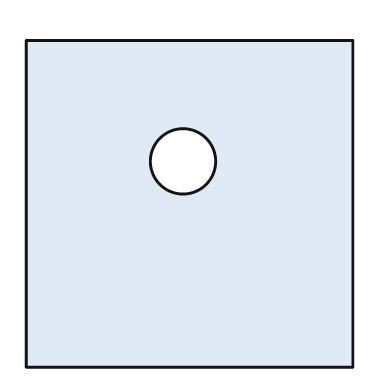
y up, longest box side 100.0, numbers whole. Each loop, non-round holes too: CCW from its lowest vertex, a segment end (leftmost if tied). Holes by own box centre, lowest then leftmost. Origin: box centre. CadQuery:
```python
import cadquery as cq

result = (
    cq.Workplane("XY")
    .moveTo(-50.0, -50.0)
    .lineTo(50.0, -50.0)
    .lineTo(50.0, 50.0)
    .lineTo(-50.0, 50.0)
    .close()
    .moveTo(-2.0, 13.0)
    .circle(10.0)
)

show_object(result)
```